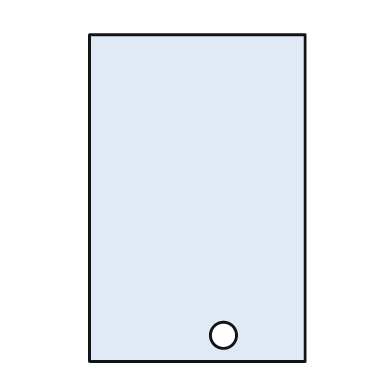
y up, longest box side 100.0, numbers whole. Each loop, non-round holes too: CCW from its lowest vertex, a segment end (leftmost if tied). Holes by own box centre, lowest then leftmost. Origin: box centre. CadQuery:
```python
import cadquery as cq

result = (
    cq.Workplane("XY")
    .moveTo(-33.0, -50.0)
    .lineTo(33.0, -50.0)
    .lineTo(33.0, 50.0)
    .lineTo(-33.0, 50.0)
    .close()
    .moveTo(8.0, -42.0)
    .circle(4.0)
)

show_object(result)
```